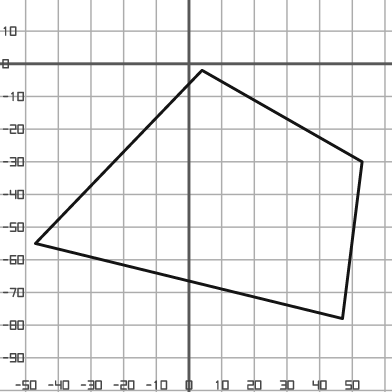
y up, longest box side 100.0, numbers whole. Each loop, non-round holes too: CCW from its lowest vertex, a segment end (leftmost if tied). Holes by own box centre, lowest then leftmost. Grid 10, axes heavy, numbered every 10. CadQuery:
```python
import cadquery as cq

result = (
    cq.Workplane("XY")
    .moveTo(47.0, -78.0)
    .lineTo(53.0, -30.0)
    .lineTo(4.0, -2.0)
    .lineTo(-47.0, -55.0)
    .close()
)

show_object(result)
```